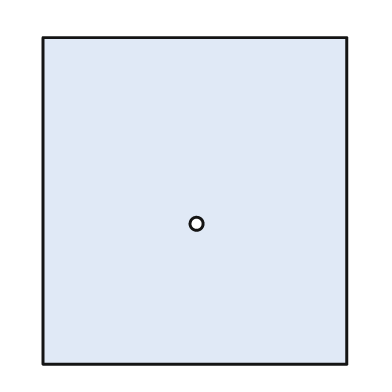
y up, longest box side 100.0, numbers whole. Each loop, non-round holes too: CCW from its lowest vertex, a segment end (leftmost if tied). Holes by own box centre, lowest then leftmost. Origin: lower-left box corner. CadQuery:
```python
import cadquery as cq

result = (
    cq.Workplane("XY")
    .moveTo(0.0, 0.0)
    .lineTo(93.0, 0.0)
    .lineTo(93.0, 100.0)
    .lineTo(0.0, 100.0)
    .close()
    .moveTo(47.0, 43.0)
    .circle(2.0)
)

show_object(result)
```